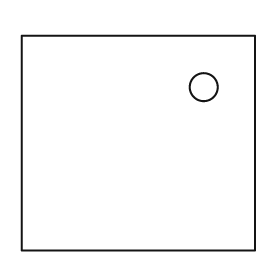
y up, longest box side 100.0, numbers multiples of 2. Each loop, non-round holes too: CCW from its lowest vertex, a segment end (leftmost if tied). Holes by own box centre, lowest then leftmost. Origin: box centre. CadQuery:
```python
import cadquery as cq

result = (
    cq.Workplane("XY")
    .moveTo(-50.0, -46.0)
    .lineTo(50.0, -46.0)
    .lineTo(50.0, 46.0)
    .lineTo(-50.0, 46.0)
    .close()
    .moveTo(28.0, 24.0)
    .circle(6.0)
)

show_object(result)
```